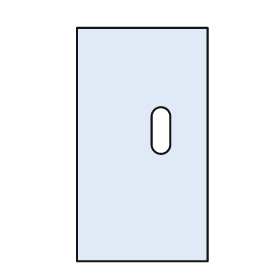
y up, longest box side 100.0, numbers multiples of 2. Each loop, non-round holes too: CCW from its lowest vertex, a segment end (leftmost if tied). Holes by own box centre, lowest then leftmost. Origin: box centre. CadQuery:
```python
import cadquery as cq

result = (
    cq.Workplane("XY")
    .moveTo(-28.0, -50.0)
    .lineTo(28.0, -50.0)
    .lineTo(28.0, 50.0)
    .lineTo(-28.0, 50.0)
    .close()
    .moveTo(4.0, 0.0)
    .threePointArc((8.0, -4.0), (12.0, 0.0))
    .lineTo(12.0, 12.0)
    .threePointArc((8.0, 16.0), (4.0, 12.0))
    .close()
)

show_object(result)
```